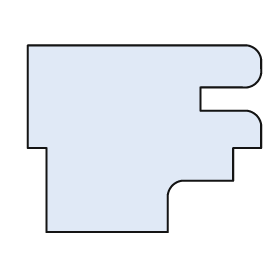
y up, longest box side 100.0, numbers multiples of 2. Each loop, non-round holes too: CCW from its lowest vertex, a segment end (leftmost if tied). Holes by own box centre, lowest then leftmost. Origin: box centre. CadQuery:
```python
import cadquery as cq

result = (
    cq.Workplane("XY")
    .moveTo(-42.0, -40.0)
    .lineTo(10.0, -40.0)
    .lineTo(10.0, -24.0)
    .threePointArc((12.0, -20.0), (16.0, -18.0))
    .lineTo(38.0, -18.0)
    .lineTo(38.0, -4.0)
    .lineTo(50.0, -4.0)
    .lineTo(50.0, 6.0)
    .threePointArc((48.0, 10.0), (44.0, 12.0))
    .lineTo(24.0, 12.0)
    .lineTo(24.0, 22.0)
    .lineTo(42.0, 22.0)
    .threePointArc((48.0, 24.0), (50.0, 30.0))
    .lineTo(50.0, 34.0)
    .threePointArc((48.0, 38.0), (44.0, 40.0))
    .lineTo(-50.0, 40.0)
    .lineTo(-50.0, -4.0)
    .lineTo(-42.0, -4.0)
    .close()
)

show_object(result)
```